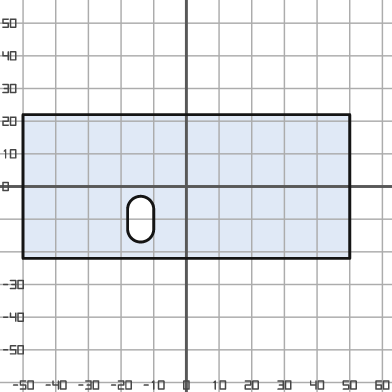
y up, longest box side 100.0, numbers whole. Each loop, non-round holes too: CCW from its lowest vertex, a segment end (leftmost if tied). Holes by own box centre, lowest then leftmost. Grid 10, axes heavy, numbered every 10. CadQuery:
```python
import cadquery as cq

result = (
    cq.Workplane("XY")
    .moveTo(-50.0, -22.0)
    .lineTo(50.0, -22.0)
    .lineTo(50.0, 22.0)
    .lineTo(-50.0, 22.0)
    .close()
    .moveTo(-18.0, -13.0)
    .threePointArc((-14.0, -17.0), (-10.0, -13.0))
    .lineTo(-10.0, -7.0)
    .threePointArc((-14.0, -3.0), (-18.0, -7.0))
    .close()
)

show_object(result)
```